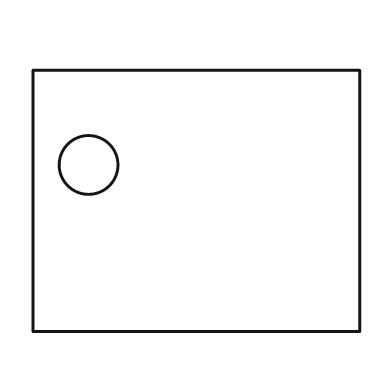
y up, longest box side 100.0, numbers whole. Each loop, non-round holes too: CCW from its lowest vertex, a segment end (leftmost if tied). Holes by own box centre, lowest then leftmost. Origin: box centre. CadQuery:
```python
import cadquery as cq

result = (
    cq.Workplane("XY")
    .moveTo(-50.0, -40.0)
    .lineTo(50.0, -40.0)
    .lineTo(50.0, 40.0)
    .lineTo(-50.0, 40.0)
    .close()
    .moveTo(-33.0, 11.0)
    .circle(9.0)
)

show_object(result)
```